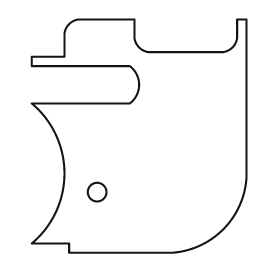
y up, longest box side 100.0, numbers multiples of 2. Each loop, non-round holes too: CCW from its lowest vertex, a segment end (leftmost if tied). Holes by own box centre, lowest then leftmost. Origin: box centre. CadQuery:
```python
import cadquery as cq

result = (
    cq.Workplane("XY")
    .moveTo(-30.0, -50.0)
    .lineTo(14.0, -50.0)
    .threePointArc((36.0, -40.0), (46.0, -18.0))
    .lineTo(46.0, 50.0)
    .lineTo(42.0, 50.0)
    .lineTo(42.0, 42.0)
    .threePointArc((40.0, 38.0), (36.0, 36.0))
    .lineTo(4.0, 36.0)
    .threePointArc((0.0, 38.0), (-2.0, 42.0))
    .lineTo(-2.0, 50.0)
    .lineTo(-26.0, 50.0)
    .threePointArc((-30.0, 48.0), (-32.0, 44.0))
    .lineTo(-32.0, 34.0)
    .lineTo(-46.0, 34.0)
    .lineTo(-46.0, 30.0)
    .lineTo(-4.0, 30.0)
    .threePointArc((0.0, 22.0), (-4.0, 14.0))
    .lineTo(-46.0, 14.0)
    .threePointArc((-32.0, -16.0), (-46.0, -46.0))
    .lineTo(-30.0, -46.0)
    .close()
    .moveTo(-18.0, -24.0)
    .circle(4.0)
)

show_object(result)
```